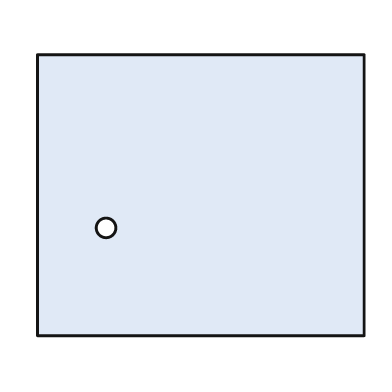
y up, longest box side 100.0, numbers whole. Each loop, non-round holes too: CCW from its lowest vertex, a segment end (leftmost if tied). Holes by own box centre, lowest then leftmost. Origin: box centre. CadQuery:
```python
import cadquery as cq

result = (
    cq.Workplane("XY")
    .moveTo(-50.0, -43.0)
    .lineTo(50.0, -43.0)
    .lineTo(50.0, 43.0)
    .lineTo(-50.0, 43.0)
    .close()
    .moveTo(-29.0, -10.0)
    .circle(3.0)
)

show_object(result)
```